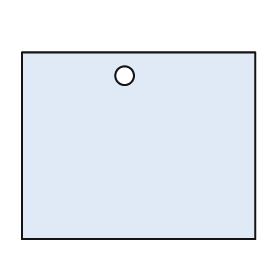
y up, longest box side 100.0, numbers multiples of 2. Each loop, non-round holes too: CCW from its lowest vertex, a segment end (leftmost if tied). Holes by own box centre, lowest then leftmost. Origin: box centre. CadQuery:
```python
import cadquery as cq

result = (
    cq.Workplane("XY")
    .moveTo(-50.0, -40.0)
    .lineTo(50.0, -40.0)
    .lineTo(50.0, 40.0)
    .lineTo(-50.0, 40.0)
    .close()
    .moveTo(-6.0, 30.0)
    .circle(4.0)
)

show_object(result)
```